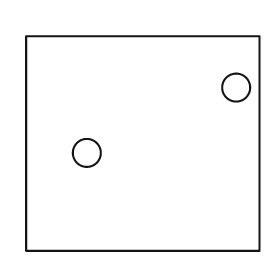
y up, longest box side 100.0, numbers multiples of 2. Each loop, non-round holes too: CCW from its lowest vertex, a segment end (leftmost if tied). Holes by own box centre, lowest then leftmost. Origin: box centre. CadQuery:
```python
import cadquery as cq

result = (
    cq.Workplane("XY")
    .moveTo(-50.0, -46.0)
    .lineTo(50.0, -46.0)
    .lineTo(50.0, 46.0)
    .lineTo(-50.0, 46.0)
    .close()
    .moveTo(-24.0, -4.0)
    .circle(6.0)
    .moveTo(40.0, 24.0)
    .circle(6.0)
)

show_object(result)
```